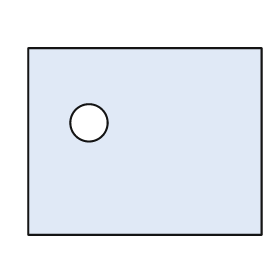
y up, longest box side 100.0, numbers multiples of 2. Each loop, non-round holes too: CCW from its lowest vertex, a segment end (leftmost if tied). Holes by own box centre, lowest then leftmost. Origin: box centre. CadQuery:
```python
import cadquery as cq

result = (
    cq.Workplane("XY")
    .moveTo(-50.0, -40.0)
    .lineTo(50.0, -40.0)
    .lineTo(50.0, 40.0)
    .lineTo(-50.0, 40.0)
    .close()
    .moveTo(-24.0, 8.0)
    .circle(8.0)
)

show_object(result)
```